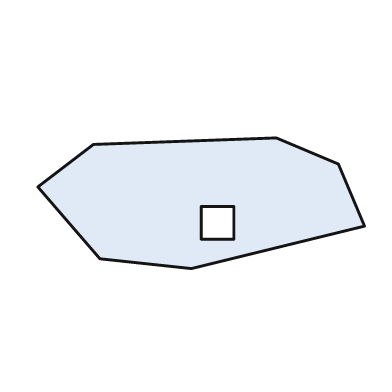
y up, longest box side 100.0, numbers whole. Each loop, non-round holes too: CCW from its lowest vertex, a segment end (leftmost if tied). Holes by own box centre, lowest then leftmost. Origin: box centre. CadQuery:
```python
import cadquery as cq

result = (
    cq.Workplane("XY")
    .moveTo(-3.0, -20.0)
    .lineTo(50.0, -7.0)
    .lineTo(42.0, 12.0)
    .lineTo(23.0, 20.0)
    .lineTo(-33.0, 18.0)
    .lineTo(-50.0, 5.0)
    .lineTo(-31.0, -17.0)
    .close()
    .moveTo(0.0, -11.0)
    .lineTo(10.0, -11.0)
    .lineTo(10.0, -1.0)
    .lineTo(0.0, -1.0)
    .close()
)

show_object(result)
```